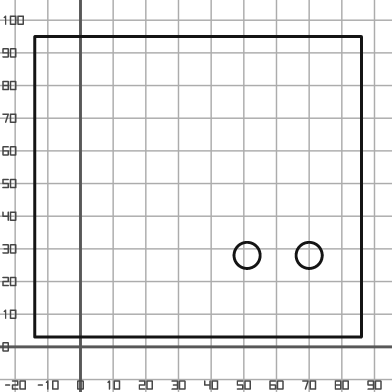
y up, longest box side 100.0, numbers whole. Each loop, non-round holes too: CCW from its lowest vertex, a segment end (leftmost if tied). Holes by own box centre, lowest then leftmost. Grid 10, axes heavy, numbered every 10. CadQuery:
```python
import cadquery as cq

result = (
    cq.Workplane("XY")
    .moveTo(-14.0, 3.0)
    .lineTo(86.0, 3.0)
    .lineTo(86.0, 95.0)
    .lineTo(-14.0, 95.0)
    .close()
    .moveTo(51.0, 28.0)
    .circle(4.0)
    .moveTo(70.0, 28.0)
    .circle(4.0)
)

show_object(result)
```